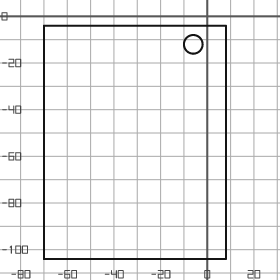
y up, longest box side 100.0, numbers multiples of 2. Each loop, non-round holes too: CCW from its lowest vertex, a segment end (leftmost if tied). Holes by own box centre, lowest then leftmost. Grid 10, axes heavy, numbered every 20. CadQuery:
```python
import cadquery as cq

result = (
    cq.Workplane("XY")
    .moveTo(-70.0, -104.0)
    .lineTo(8.0, -104.0)
    .lineTo(8.0, -4.0)
    .lineTo(-70.0, -4.0)
    .close()
    .moveTo(-6.0, -12.0)
    .circle(4.0)
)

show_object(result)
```